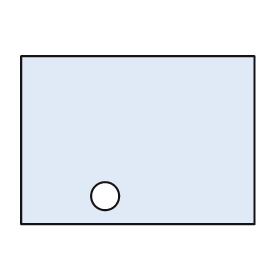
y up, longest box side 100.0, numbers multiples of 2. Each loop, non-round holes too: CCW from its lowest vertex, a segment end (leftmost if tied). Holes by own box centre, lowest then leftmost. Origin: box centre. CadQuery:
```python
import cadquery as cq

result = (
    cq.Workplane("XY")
    .moveTo(-50.0, -36.0)
    .lineTo(50.0, -36.0)
    .lineTo(50.0, 36.0)
    .lineTo(-50.0, 36.0)
    .close()
    .moveTo(-14.0, -24.0)
    .circle(6.0)
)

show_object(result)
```